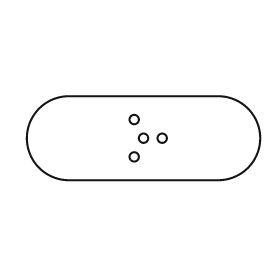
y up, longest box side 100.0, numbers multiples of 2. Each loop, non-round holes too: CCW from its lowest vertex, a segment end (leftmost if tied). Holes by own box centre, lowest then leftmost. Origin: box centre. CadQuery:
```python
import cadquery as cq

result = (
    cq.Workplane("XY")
    .moveTo(-32.0, -18.0)
    .lineTo(32.0, -18.0)
    .threePointArc((50.0, 0.0), (32.0, 18.0))
    .lineTo(-32.0, 18.0)
    .threePointArc((-50.0, 0.0), (-32.0, -18.0))
    .close()
    .moveTo(-4.0, -8.0)
    .circle(2.0)
    .moveTo(0.0, 0.0)
    .circle(2.0)
    .moveTo(8.0, 0.0)
    .circle(2.0)
    .moveTo(-4.0, 8.0)
    .circle(2.0)
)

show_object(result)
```